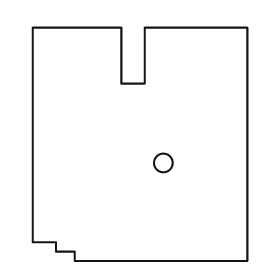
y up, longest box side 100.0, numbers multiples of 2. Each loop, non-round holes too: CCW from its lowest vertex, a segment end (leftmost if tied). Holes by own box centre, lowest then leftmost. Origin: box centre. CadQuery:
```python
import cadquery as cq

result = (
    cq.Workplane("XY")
    .moveTo(-28.0, -50.0)
    .lineTo(46.0, -50.0)
    .lineTo(46.0, 50.0)
    .lineTo(2.0, 50.0)
    .lineTo(2.0, 26.0)
    .lineTo(-8.0, 26.0)
    .lineTo(-8.0, 50.0)
    .lineTo(-46.0, 50.0)
    .lineTo(-46.0, -42.0)
    .lineTo(-36.0, -42.0)
    .lineTo(-36.0, -46.0)
    .lineTo(-28.0, -46.0)
    .close()
    .moveTo(10.0, -8.0)
    .circle(4.0)
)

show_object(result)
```